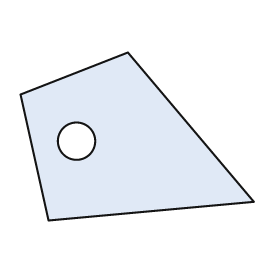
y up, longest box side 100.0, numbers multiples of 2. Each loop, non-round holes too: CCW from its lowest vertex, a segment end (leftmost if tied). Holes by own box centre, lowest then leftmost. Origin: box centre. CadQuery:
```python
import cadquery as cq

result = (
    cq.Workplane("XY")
    .moveTo(-38.0, -36.0)
    .lineTo(50.0, -28.0)
    .lineTo(-4.0, 36.0)
    .lineTo(-50.0, 18.0)
    .close()
    .moveTo(-26.0, -2.0)
    .circle(8.0)
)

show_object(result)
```